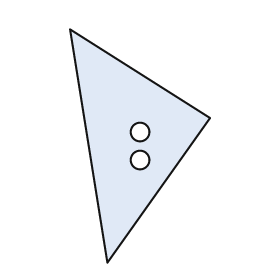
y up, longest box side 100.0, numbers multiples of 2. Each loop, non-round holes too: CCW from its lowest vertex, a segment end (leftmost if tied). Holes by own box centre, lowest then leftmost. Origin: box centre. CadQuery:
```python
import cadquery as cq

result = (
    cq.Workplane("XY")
    .moveTo(-14.0, -50.0)
    .lineTo(30.0, 12.0)
    .lineTo(-30.0, 50.0)
    .close()
    .moveTo(0.0, -6.0)
    .circle(4.0)
    .moveTo(0.0, 6.0)
    .circle(4.0)
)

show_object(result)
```